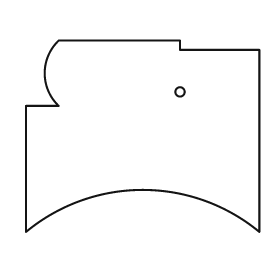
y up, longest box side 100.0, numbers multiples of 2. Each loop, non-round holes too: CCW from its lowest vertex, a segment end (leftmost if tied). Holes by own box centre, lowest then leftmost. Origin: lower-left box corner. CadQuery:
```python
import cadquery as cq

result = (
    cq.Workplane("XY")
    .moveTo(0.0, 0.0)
    .threePointArc((50.0, 18.0), (100.0, 0.0))
    .lineTo(100.0, 78.0)
    .lineTo(66.0, 78.0)
    .lineTo(66.0, 82.0)
    .lineTo(14.0, 82.0)
    .threePointArc((8.0, 68.0), (14.0, 54.0))
    .lineTo(0.0, 54.0)
    .close()
    .moveTo(66.0, 60.0)
    .circle(2.0)
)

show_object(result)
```